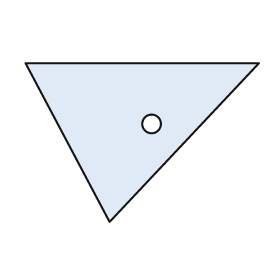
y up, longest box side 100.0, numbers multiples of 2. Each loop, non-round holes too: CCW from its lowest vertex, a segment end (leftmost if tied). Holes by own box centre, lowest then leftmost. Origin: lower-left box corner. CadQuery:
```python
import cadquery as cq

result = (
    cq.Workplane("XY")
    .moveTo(36.0, 0.0)
    .lineTo(100.0, 68.0)
    .lineTo(0.0, 68.0)
    .close()
    .moveTo(54.0, 42.0)
    .circle(4.0)
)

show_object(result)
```